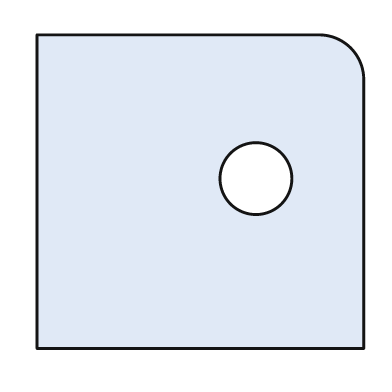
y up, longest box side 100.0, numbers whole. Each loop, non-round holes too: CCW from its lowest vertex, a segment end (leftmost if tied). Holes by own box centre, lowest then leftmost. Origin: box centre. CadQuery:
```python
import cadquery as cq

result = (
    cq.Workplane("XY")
    .moveTo(-50.0, -48.0)
    .lineTo(50.0, -48.0)
    .lineTo(50.0, 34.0)
    .threePointArc((46.0, 44.0), (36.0, 48.0))
    .lineTo(-50.0, 48.0)
    .close()
    .moveTo(17.0, 4.0)
    .circle(11.0)
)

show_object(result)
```